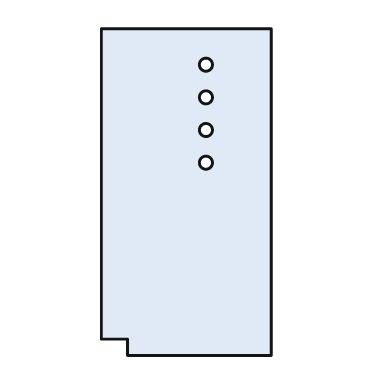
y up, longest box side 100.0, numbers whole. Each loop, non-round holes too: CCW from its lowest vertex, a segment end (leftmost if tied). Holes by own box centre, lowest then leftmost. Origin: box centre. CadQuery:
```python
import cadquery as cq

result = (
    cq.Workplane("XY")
    .moveTo(-18.0, -50.0)
    .lineTo(26.0, -50.0)
    .lineTo(26.0, 50.0)
    .lineTo(-26.0, 50.0)
    .lineTo(-26.0, -45.0)
    .lineTo(-18.0, -45.0)
    .close()
    .moveTo(6.0, 9.0)
    .circle(2.0)
    .moveTo(6.0, 19.0)
    .circle(2.0)
    .moveTo(6.0, 29.0)
    .circle(2.0)
    .moveTo(6.0, 39.0)
    .circle(2.0)
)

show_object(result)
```